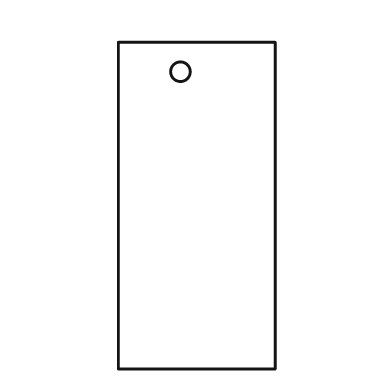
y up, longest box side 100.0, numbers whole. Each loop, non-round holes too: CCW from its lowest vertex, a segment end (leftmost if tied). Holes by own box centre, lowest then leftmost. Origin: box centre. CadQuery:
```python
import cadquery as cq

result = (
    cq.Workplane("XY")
    .moveTo(-24.0, -50.0)
    .lineTo(24.0, -50.0)
    .lineTo(24.0, 50.0)
    .lineTo(-24.0, 50.0)
    .close()
    .moveTo(-5.0, 41.0)
    .circle(3.0)
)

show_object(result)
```